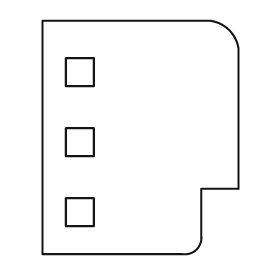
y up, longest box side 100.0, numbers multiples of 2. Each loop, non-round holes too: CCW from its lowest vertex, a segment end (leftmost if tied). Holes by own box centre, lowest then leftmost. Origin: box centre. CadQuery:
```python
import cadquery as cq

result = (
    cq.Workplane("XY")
    .moveTo(-42.0, -50.0)
    .lineTo(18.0, -50.0)
    .threePointArc((24.0, -48.0), (26.0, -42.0))
    .lineTo(26.0, -22.0)
    .lineTo(42.0, -22.0)
    .lineTo(42.0, 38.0)
    .threePointArc((38.0, 46.0), (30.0, 50.0))
    .lineTo(-42.0, 50.0)
    .close()
    .moveTo(-32.0, -38.0)
    .lineTo(-20.0, -38.0)
    .lineTo(-20.0, -26.0)
    .lineTo(-32.0, -26.0)
    .close()
    .moveTo(-32.0, -8.0)
    .lineTo(-20.0, -8.0)
    .lineTo(-20.0, 4.0)
    .lineTo(-32.0, 4.0)
    .close()
    .moveTo(-32.0, 22.0)
    .lineTo(-20.0, 22.0)
    .lineTo(-20.0, 34.0)
    .lineTo(-32.0, 34.0)
    .close()
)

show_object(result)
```